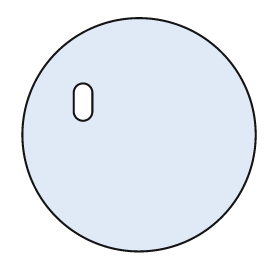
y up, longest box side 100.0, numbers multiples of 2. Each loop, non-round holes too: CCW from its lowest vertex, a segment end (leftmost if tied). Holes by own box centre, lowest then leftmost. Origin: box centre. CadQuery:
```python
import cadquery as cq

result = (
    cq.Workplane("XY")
    .moveTo(0.0, 0.0)
    .circle(50.0)
    .moveTo(-28.0, 10.0)
    .threePointArc((-24.0, 6.0), (-20.0, 10.0))
    .lineTo(-20.0, 18.0)
    .threePointArc((-24.0, 22.0), (-28.0, 18.0))
    .close()
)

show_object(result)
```